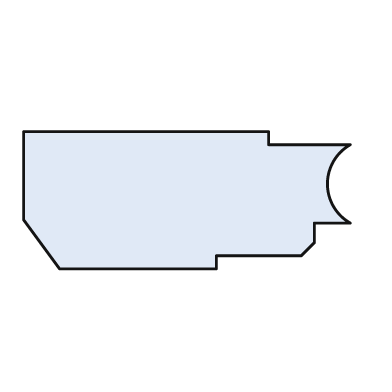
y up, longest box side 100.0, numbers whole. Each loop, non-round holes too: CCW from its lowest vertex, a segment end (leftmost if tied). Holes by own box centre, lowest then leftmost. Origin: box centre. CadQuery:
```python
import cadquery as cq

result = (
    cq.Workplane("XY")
    .moveTo(-39.0, -21.0)
    .lineTo(9.0, -21.0)
    .lineTo(9.0, -17.0)
    .lineTo(35.0, -17.0)
    .lineTo(39.0, -13.0)
    .lineTo(39.0, -7.0)
    .lineTo(50.0, -7.0)
    .threePointArc((43.0, 5.0), (50.0, 17.0))
    .lineTo(25.0, 17.0)
    .lineTo(25.0, 21.0)
    .lineTo(-50.0, 21.0)
    .lineTo(-50.0, -6.0)
    .close()
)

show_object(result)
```